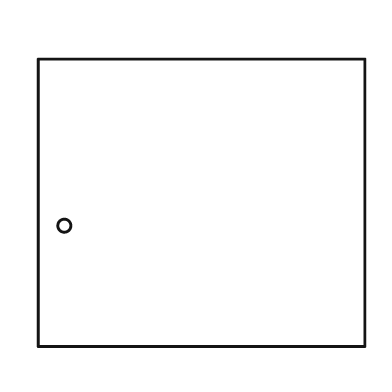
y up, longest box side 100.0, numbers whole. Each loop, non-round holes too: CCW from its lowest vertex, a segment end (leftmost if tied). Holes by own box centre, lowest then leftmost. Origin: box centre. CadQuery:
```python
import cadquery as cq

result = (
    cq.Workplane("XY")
    .moveTo(-50.0, -44.0)
    .lineTo(50.0, -44.0)
    .lineTo(50.0, 44.0)
    .lineTo(-50.0, 44.0)
    .close()
    .moveTo(-42.0, -7.0)
    .circle(2.0)
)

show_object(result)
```